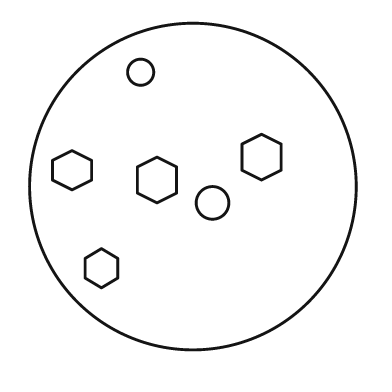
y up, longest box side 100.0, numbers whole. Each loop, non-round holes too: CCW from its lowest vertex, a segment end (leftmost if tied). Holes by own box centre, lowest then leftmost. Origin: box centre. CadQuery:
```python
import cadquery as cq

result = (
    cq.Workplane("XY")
    .moveTo(0.0, 0.0)
    .circle(50.0)
    .moveTo(-28.0, -31.0)
    .lineTo(-23.0, -28.0)
    .lineTo(-23.0, -22.0)
    .lineTo(-28.0, -19.0)
    .lineTo(-33.0, -22.0)
    .lineTo(-33.0, -28.0)
    .close()
    .moveTo(6.0, -5.0)
    .circle(5.0)
    .moveTo(-11.0, -5.0)
    .lineTo(-5.0, -2.0)
    .lineTo(-5.0, 6.0)
    .lineTo(-11.0, 9.0)
    .lineTo(-17.0, 6.0)
    .lineTo(-17.0, -2.0)
    .close()
    .moveTo(-37.0, -1.0)
    .lineTo(-31.0, 2.0)
    .lineTo(-31.0, 8.0)
    .lineTo(-37.0, 11.0)
    .lineTo(-43.0, 8.0)
    .lineTo(-43.0, 2.0)
    .close()
    .moveTo(21.0, 2.0)
    .lineTo(27.0, 5.0)
    .lineTo(27.0, 13.0)
    .lineTo(21.0, 16.0)
    .lineTo(15.0, 13.0)
    .lineTo(15.0, 5.0)
    .close()
    .moveTo(-16.0, 35.0)
    .circle(4.0)
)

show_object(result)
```